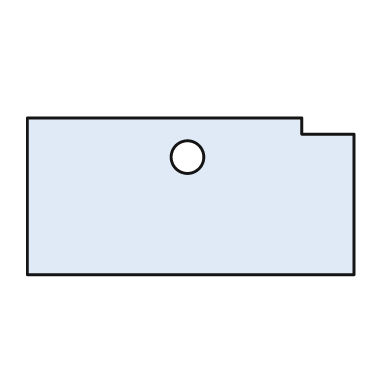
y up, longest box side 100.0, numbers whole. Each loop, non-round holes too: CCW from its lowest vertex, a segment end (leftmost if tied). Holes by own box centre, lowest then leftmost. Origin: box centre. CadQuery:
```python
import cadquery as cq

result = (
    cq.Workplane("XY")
    .moveTo(-50.0, -24.0)
    .lineTo(50.0, -24.0)
    .lineTo(50.0, 19.0)
    .lineTo(34.0, 19.0)
    .lineTo(34.0, 24.0)
    .lineTo(-50.0, 24.0)
    .close()
    .moveTo(-1.0, 12.0)
    .circle(5.0)
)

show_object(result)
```